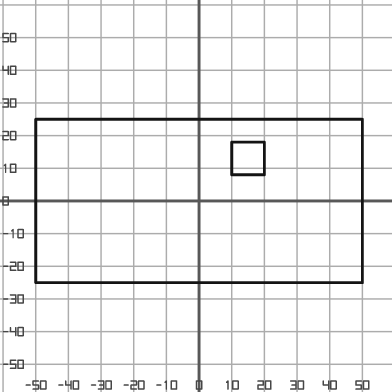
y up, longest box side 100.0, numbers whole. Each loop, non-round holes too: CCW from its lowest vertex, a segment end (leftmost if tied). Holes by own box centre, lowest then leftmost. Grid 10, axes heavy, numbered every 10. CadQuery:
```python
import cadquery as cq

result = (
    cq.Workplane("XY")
    .moveTo(-50.0, -25.0)
    .lineTo(50.0, -25.0)
    .lineTo(50.0, 25.0)
    .lineTo(-50.0, 25.0)
    .close()
    .moveTo(10.0, 8.0)
    .lineTo(20.0, 8.0)
    .lineTo(20.0, 18.0)
    .lineTo(10.0, 18.0)
    .close()
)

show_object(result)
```